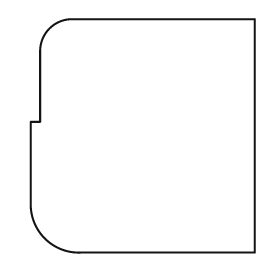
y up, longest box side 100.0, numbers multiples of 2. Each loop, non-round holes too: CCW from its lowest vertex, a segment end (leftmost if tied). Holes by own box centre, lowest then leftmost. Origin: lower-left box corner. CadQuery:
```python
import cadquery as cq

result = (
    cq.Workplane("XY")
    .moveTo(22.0, 0.0)
    .lineTo(96.0, 0.0)
    .lineTo(96.0, 100.0)
    .lineTo(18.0, 100.0)
    .threePointArc((8.0, 96.0), (4.0, 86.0))
    .lineTo(4.0, 56.0)
    .lineTo(0.0, 56.0)
    .lineTo(0.0, 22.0)
    .threePointArc((6.0, 6.0), (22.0, 0.0))
    .close()
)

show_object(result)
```